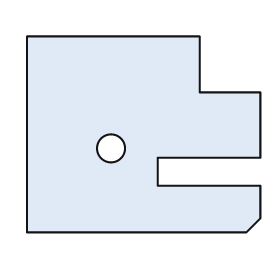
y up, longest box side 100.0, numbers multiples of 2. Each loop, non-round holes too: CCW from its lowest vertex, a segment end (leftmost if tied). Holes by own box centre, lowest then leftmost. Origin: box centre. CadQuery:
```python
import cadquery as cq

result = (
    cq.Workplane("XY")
    .moveTo(-50.0, -42.0)
    .lineTo(44.0, -42.0)
    .lineTo(50.0, -36.0)
    .lineTo(50.0, -22.0)
    .lineTo(6.0, -22.0)
    .lineTo(6.0, -10.0)
    .lineTo(50.0, -10.0)
    .lineTo(50.0, 18.0)
    .lineTo(24.0, 18.0)
    .lineTo(24.0, 42.0)
    .lineTo(-50.0, 42.0)
    .close()
    .moveTo(-14.0, -6.0)
    .circle(6.0)
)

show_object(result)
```